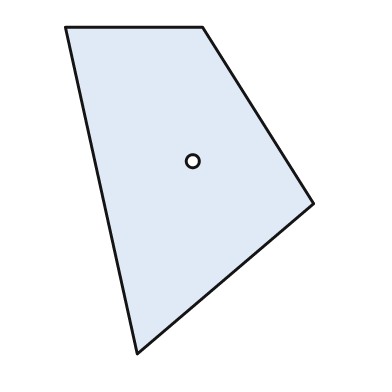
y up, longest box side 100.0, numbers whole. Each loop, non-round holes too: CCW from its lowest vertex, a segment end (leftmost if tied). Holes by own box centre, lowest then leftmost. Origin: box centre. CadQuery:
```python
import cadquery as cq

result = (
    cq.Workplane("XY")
    .moveTo(-16.0, -50.0)
    .lineTo(38.0, -4.0)
    .lineTo(4.0, 50.0)
    .lineTo(-38.0, 50.0)
    .close()
    .moveTo(1.0, 9.0)
    .circle(2.0)
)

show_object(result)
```